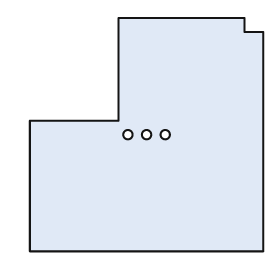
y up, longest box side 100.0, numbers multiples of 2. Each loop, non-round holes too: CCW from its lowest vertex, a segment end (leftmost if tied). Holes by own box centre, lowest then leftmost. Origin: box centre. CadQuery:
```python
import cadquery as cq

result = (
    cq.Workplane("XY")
    .moveTo(-50.0, -50.0)
    .lineTo(50.0, -50.0)
    .lineTo(50.0, 44.0)
    .lineTo(42.0, 44.0)
    .lineTo(42.0, 50.0)
    .lineTo(-12.0, 50.0)
    .lineTo(-12.0, 6.0)
    .lineTo(-50.0, 6.0)
    .close()
    .moveTo(-8.0, 0.0)
    .circle(2.0)
    .moveTo(0.0, 0.0)
    .circle(2.0)
    .moveTo(8.0, 0.0)
    .circle(2.0)
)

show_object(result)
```